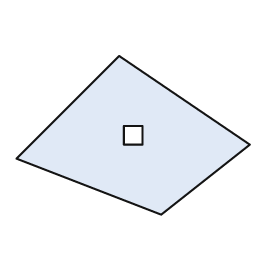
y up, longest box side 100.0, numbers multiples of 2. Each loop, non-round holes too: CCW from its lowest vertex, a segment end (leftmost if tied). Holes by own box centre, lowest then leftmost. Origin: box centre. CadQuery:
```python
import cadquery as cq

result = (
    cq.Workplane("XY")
    .moveTo(12.0, -34.0)
    .lineTo(50.0, -4.0)
    .lineTo(-6.0, 34.0)
    .lineTo(-50.0, -10.0)
    .close()
    .moveTo(-4.0, -4.0)
    .lineTo(4.0, -4.0)
    .lineTo(4.0, 4.0)
    .lineTo(-4.0, 4.0)
    .close()
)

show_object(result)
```